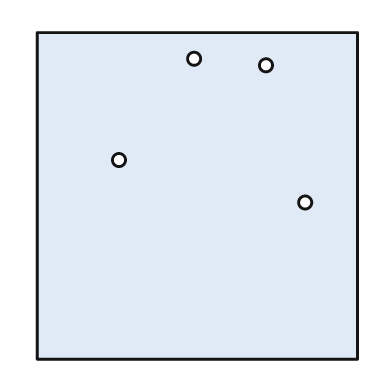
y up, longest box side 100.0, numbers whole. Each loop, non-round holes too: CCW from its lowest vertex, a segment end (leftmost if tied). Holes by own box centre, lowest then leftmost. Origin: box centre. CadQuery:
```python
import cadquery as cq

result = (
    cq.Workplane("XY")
    .moveTo(-49.0, -50.0)
    .lineTo(49.0, -50.0)
    .lineTo(49.0, 50.0)
    .lineTo(-49.0, 50.0)
    .close()
    .moveTo(33.0, -2.0)
    .circle(2.0)
    .moveTo(-24.0, 11.0)
    .circle(2.0)
    .moveTo(21.0, 40.0)
    .circle(2.0)
    .moveTo(-1.0, 42.0)
    .circle(2.0)
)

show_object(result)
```